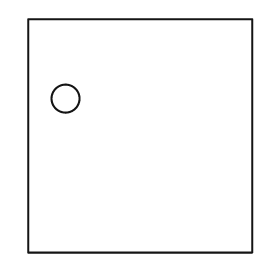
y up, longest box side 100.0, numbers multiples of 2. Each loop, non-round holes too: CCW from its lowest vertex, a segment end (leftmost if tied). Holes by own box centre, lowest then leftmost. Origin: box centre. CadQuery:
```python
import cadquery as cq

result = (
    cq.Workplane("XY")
    .moveTo(-48.0, -50.0)
    .lineTo(48.0, -50.0)
    .lineTo(48.0, 50.0)
    .lineTo(-48.0, 50.0)
    .close()
    .moveTo(-32.0, 16.0)
    .circle(6.0)
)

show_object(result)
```